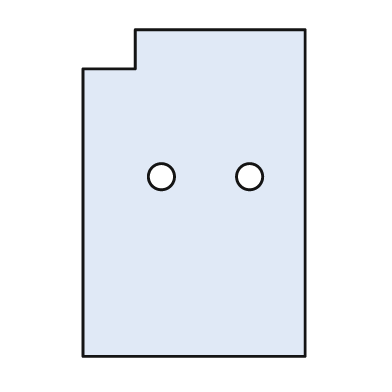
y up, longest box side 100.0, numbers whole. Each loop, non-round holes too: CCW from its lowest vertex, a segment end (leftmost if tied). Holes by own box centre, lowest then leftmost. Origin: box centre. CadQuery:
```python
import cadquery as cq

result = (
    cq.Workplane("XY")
    .moveTo(-34.0, -50.0)
    .lineTo(34.0, -50.0)
    .lineTo(34.0, 50.0)
    .lineTo(-18.0, 50.0)
    .lineTo(-18.0, 38.0)
    .lineTo(-34.0, 38.0)
    .close()
    .moveTo(-10.0, 5.0)
    .circle(4.0)
    .moveTo(17.0, 5.0)
    .circle(4.0)
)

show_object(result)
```